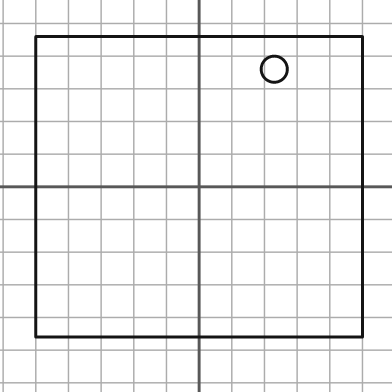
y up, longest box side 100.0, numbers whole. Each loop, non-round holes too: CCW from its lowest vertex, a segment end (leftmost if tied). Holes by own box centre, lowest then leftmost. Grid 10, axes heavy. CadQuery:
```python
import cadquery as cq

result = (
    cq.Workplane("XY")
    .moveTo(-50.0, -46.0)
    .lineTo(50.0, -46.0)
    .lineTo(50.0, 46.0)
    .lineTo(-50.0, 46.0)
    .close()
    .moveTo(23.0, 36.0)
    .circle(4.0)
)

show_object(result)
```